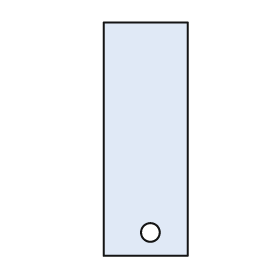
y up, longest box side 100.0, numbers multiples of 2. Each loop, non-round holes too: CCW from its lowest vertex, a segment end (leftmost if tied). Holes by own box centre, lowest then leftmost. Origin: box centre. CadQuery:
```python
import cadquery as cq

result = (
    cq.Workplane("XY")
    .moveTo(-18.0, -50.0)
    .lineTo(18.0, -50.0)
    .lineTo(18.0, 50.0)
    .lineTo(-18.0, 50.0)
    .close()
    .moveTo(2.0, -40.0)
    .circle(4.0)
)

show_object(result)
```